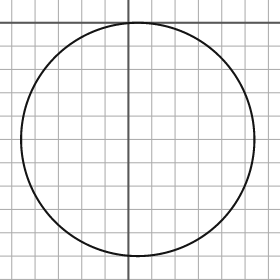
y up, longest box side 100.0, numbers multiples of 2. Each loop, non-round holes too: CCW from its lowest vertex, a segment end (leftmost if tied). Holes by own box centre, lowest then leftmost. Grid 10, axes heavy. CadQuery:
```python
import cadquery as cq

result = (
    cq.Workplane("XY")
    .moveTo(4.0, -50.0)
    .circle(50.0)
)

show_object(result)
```